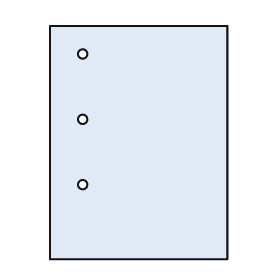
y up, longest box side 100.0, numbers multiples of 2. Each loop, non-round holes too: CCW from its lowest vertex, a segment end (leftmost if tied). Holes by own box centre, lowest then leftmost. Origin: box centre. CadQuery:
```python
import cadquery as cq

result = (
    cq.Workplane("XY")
    .moveTo(-38.0, -50.0)
    .lineTo(38.0, -50.0)
    .lineTo(38.0, 50.0)
    .lineTo(-38.0, 50.0)
    .close()
    .moveTo(-24.0, -18.0)
    .circle(2.0)
    .moveTo(-24.0, 10.0)
    .circle(2.0)
    .moveTo(-24.0, 38.0)
    .circle(2.0)
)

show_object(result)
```